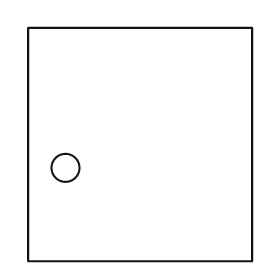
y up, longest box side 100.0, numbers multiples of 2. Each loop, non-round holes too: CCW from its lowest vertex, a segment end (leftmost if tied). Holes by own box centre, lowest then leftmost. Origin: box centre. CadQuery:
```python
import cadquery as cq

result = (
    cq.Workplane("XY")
    .moveTo(-48.0, -50.0)
    .lineTo(48.0, -50.0)
    .lineTo(48.0, 50.0)
    .lineTo(-48.0, 50.0)
    .close()
    .moveTo(-32.0, -10.0)
    .circle(6.0)
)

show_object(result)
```